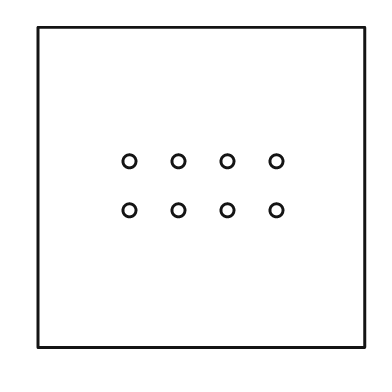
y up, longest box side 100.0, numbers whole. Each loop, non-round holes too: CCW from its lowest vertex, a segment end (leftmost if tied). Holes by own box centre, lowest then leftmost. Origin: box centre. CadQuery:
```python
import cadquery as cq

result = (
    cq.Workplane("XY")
    .moveTo(-50.0, -49.0)
    .lineTo(50.0, -49.0)
    .lineTo(50.0, 49.0)
    .lineTo(-50.0, 49.0)
    .close()
    .moveTo(-22.0, -7.0)
    .circle(2.0)
    .moveTo(-7.0, -7.0)
    .circle(2.0)
    .moveTo(8.0, -7.0)
    .circle(2.0)
    .moveTo(23.0, -7.0)
    .circle(2.0)
    .moveTo(-22.0, 8.0)
    .circle(2.0)
    .moveTo(-7.0, 8.0)
    .circle(2.0)
    .moveTo(8.0, 8.0)
    .circle(2.0)
    .moveTo(23.0, 8.0)
    .circle(2.0)
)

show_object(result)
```